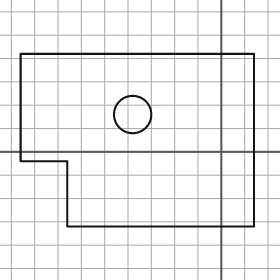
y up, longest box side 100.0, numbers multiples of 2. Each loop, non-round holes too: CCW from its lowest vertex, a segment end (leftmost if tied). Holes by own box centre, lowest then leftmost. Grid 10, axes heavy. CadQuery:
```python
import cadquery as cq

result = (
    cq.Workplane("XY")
    .moveTo(-66.0, -32.0)
    .lineTo(14.0, -32.0)
    .lineTo(14.0, 42.0)
    .lineTo(-86.0, 42.0)
    .lineTo(-86.0, -4.0)
    .lineTo(-66.0, -4.0)
    .close()
    .moveTo(-38.0, 16.0)
    .circle(8.0)
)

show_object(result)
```